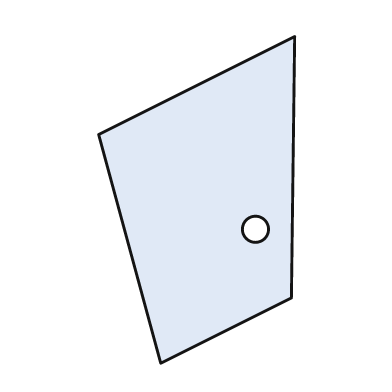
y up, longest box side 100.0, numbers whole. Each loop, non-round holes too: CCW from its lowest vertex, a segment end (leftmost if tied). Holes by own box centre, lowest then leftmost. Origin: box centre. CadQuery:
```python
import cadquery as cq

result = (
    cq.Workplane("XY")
    .moveTo(-11.0, -50.0)
    .lineTo(29.0, -30.0)
    .lineTo(30.0, 50.0)
    .lineTo(-30.0, 20.0)
    .close()
    .moveTo(18.0, -9.0)
    .circle(4.0)
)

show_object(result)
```